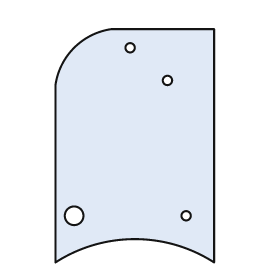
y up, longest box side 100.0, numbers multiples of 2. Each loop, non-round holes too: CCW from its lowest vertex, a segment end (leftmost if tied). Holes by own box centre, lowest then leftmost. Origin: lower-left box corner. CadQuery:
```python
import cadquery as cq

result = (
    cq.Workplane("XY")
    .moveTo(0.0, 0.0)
    .threePointArc((34.0, 10.0), (68.0, 0.0))
    .lineTo(68.0, 100.0)
    .lineTo(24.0, 100.0)
    .threePointArc((8.0, 92.0), (0.0, 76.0))
    .close()
    .moveTo(8.0, 20.0)
    .circle(4.0)
    .moveTo(56.0, 20.0)
    .circle(2.0)
    .moveTo(48.0, 78.0)
    .circle(2.0)
    .moveTo(32.0, 92.0)
    .circle(2.0)
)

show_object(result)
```